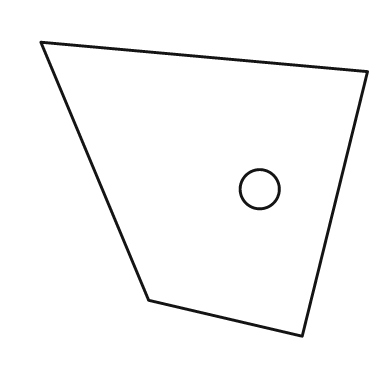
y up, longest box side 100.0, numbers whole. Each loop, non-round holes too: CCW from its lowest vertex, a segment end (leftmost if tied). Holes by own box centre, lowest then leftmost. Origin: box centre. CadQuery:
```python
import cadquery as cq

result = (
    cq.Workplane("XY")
    .moveTo(30.0, -45.0)
    .lineTo(50.0, 36.0)
    .lineTo(-50.0, 45.0)
    .lineTo(-17.0, -34.0)
    .close()
    .moveTo(17.0, 0.0)
    .circle(6.0)
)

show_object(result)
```